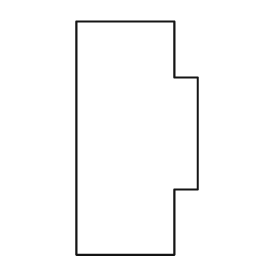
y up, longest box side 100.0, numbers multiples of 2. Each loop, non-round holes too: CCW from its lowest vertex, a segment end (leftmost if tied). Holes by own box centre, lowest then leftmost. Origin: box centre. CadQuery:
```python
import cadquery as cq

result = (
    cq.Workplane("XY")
    .moveTo(-26.0, -50.0)
    .lineTo(16.0, -50.0)
    .lineTo(16.0, -22.0)
    .lineTo(26.0, -22.0)
    .lineTo(26.0, 26.0)
    .lineTo(16.0, 26.0)
    .lineTo(16.0, 50.0)
    .lineTo(-26.0, 50.0)
    .close()
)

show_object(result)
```